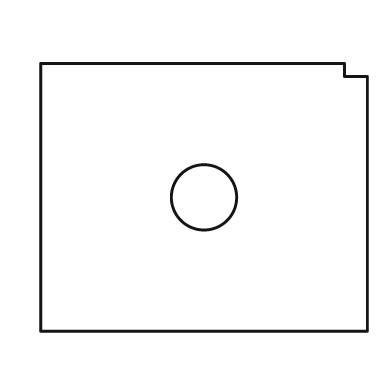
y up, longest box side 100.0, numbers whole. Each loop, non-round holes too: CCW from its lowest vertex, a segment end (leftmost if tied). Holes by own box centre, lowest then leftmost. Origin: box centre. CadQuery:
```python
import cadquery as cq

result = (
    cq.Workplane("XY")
    .moveTo(-50.0, -41.0)
    .lineTo(50.0, -41.0)
    .lineTo(50.0, 37.0)
    .lineTo(43.0, 37.0)
    .lineTo(43.0, 41.0)
    .lineTo(-50.0, 41.0)
    .close()
    .moveTo(0.0, 0.0)
    .circle(10.0)
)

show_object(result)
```